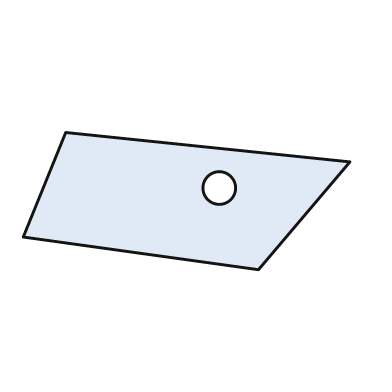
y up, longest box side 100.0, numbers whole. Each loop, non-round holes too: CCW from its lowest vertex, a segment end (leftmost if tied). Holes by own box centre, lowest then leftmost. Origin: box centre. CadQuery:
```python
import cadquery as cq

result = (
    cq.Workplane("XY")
    .moveTo(22.0, -21.0)
    .lineTo(50.0, 12.0)
    .lineTo(-37.0, 21.0)
    .lineTo(-50.0, -11.0)
    .close()
    .moveTo(10.0, 4.0)
    .circle(5.0)
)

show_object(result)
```